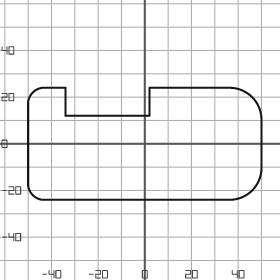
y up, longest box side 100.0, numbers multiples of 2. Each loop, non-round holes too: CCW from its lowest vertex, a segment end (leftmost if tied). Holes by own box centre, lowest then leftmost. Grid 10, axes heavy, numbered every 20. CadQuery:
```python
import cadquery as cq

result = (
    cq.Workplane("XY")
    .moveTo(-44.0, -24.0)
    .lineTo(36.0, -24.0)
    .threePointArc((46.0, -20.0), (50.0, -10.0))
    .lineTo(50.0, 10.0)
    .threePointArc((46.0, 20.0), (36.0, 24.0))
    .lineTo(2.0, 24.0)
    .lineTo(2.0, 12.0)
    .lineTo(-34.0, 12.0)
    .lineTo(-34.0, 24.0)
    .lineTo(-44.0, 24.0)
    .threePointArc((-48.0, 22.0), (-50.0, 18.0))
    .lineTo(-50.0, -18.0)
    .threePointArc((-48.0, -22.0), (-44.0, -24.0))
    .close()
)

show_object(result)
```